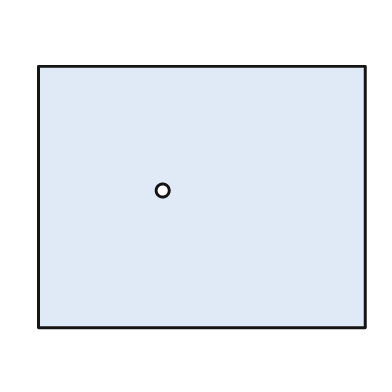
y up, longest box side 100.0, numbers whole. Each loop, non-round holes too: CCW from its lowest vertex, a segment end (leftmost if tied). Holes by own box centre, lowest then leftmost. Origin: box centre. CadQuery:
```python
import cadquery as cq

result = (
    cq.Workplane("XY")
    .moveTo(-50.0, -40.0)
    .lineTo(50.0, -40.0)
    .lineTo(50.0, 40.0)
    .lineTo(-50.0, 40.0)
    .close()
    .moveTo(-12.0, 2.0)
    .circle(2.0)
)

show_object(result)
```